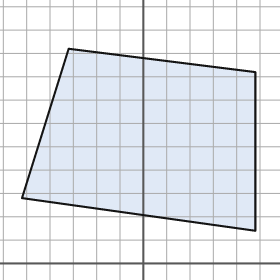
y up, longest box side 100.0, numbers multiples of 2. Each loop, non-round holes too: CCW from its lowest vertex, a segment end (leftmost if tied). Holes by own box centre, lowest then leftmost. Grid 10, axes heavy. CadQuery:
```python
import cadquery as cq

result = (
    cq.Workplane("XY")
    .moveTo(48.0, 14.0)
    .lineTo(48.0, 82.0)
    .lineTo(-32.0, 92.0)
    .lineTo(-52.0, 28.0)
    .close()
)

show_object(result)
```